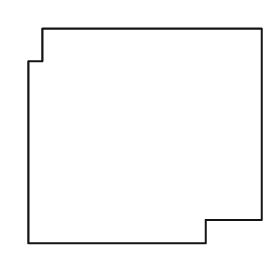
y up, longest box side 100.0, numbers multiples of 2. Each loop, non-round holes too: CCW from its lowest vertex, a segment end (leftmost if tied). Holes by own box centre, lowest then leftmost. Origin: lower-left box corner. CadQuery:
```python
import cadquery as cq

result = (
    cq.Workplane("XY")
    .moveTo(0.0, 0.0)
    .lineTo(76.0, 0.0)
    .lineTo(76.0, 10.0)
    .lineTo(100.0, 10.0)
    .lineTo(100.0, 92.0)
    .lineTo(6.0, 92.0)
    .lineTo(6.0, 78.0)
    .lineTo(0.0, 78.0)
    .close()
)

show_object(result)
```